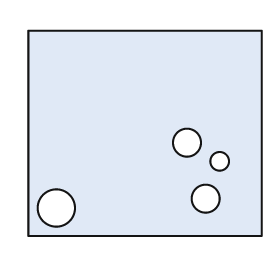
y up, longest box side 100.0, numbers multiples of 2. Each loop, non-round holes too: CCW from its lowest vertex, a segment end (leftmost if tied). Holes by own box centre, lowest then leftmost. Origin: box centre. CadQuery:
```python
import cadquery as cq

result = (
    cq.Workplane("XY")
    .moveTo(-50.0, -44.0)
    .lineTo(50.0, -44.0)
    .lineTo(50.0, 44.0)
    .lineTo(-50.0, 44.0)
    .close()
    .moveTo(-38.0, -32.0)
    .circle(8.0)
    .moveTo(26.0, -28.0)
    .circle(6.0)
    .moveTo(32.0, -12.0)
    .circle(4.0)
    .moveTo(18.0, -4.0)
    .circle(6.0)
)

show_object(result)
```